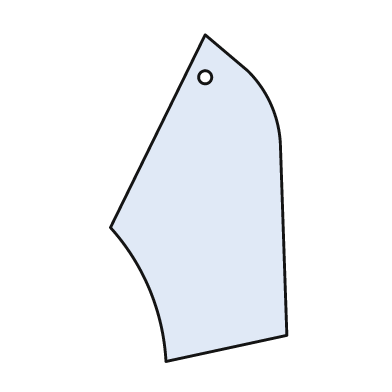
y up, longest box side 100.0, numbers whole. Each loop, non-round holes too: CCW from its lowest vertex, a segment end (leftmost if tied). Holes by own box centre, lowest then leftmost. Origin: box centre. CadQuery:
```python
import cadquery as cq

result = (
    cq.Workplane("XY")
    .moveTo(-10.0, -50.0)
    .lineTo(27.0, -42.0)
    .lineTo(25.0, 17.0)
    .threePointArc((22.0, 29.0), (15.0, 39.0))
    .lineTo(2.0, 50.0)
    .lineTo(-27.0, -9.0)
    .threePointArc((-15.0, -28.0), (-10.0, -50.0))
    .close()
    .moveTo(2.0, 37.0)
    .circle(2.0)
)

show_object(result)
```